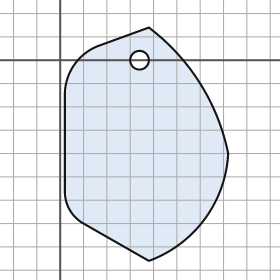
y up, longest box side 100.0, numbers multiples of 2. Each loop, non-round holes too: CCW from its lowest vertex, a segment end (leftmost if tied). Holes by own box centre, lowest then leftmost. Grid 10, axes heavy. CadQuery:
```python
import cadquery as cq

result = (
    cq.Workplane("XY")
    .moveTo(38.0, -86.0)
    .threePointArc((62.0, -68.0), (72.0, -40.0))
    .threePointArc((60.0, -10.0), (38.0, 14.0))
    .lineTo(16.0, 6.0)
    .threePointArc((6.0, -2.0), (2.0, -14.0))
    .lineTo(2.0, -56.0)
    .threePointArc((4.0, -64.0), (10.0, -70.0))
    .close()
    .moveTo(34.0, 0.0)
    .circle(4.0)
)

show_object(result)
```